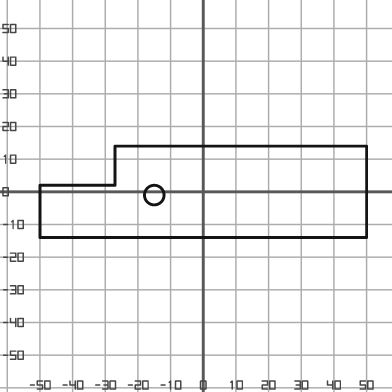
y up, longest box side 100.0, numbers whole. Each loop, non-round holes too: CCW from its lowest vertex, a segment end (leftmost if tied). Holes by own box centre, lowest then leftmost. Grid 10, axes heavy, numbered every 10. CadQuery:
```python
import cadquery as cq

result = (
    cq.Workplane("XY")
    .moveTo(-50.0, -14.0)
    .lineTo(50.0, -14.0)
    .lineTo(50.0, 14.0)
    .lineTo(-27.0, 14.0)
    .lineTo(-27.0, 2.0)
    .lineTo(-50.0, 2.0)
    .close()
    .moveTo(-15.0, -1.0)
    .circle(3.0)
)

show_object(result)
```